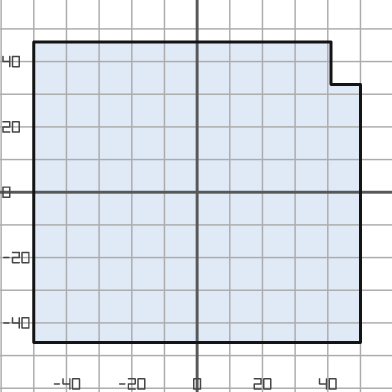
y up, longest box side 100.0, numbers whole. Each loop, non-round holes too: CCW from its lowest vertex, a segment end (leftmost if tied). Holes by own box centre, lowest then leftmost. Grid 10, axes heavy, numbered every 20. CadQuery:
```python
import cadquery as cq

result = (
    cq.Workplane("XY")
    .moveTo(-50.0, -46.0)
    .lineTo(50.0, -46.0)
    .lineTo(50.0, 33.0)
    .lineTo(41.0, 33.0)
    .lineTo(41.0, 46.0)
    .lineTo(-50.0, 46.0)
    .close()
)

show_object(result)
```